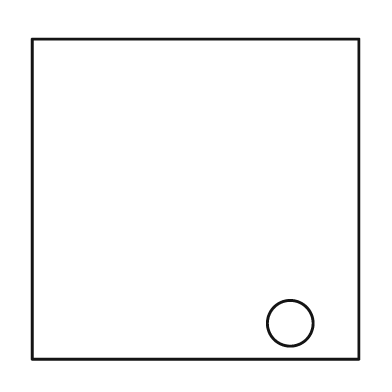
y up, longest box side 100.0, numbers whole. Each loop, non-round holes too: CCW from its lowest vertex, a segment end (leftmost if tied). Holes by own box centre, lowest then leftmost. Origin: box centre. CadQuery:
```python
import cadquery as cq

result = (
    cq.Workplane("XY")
    .moveTo(-50.0, -49.0)
    .lineTo(50.0, -49.0)
    .lineTo(50.0, 49.0)
    .lineTo(-50.0, 49.0)
    .close()
    .moveTo(29.0, -38.0)
    .circle(7.0)
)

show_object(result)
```